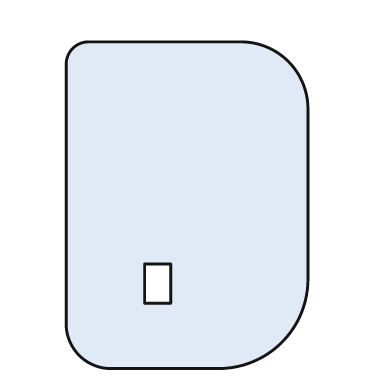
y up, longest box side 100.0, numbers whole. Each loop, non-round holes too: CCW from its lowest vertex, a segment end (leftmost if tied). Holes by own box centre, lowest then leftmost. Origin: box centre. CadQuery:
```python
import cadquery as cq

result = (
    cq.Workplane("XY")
    .moveTo(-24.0, -50.0)
    .lineTo(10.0, -50.0)
    .threePointArc((29.0, -42.0), (37.0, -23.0))
    .lineTo(37.0, 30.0)
    .threePointArc((31.0, 44.0), (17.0, 50.0))
    .lineTo(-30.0, 50.0)
    .threePointArc((-35.0, 48.0), (-37.0, 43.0))
    .lineTo(-37.0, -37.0)
    .threePointArc((-33.0, -46.0), (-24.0, -50.0))
    .close()
    .moveTo(-13.0, -30.0)
    .lineTo(-5.0, -30.0)
    .lineTo(-5.0, -18.0)
    .lineTo(-13.0, -18.0)
    .close()
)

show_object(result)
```